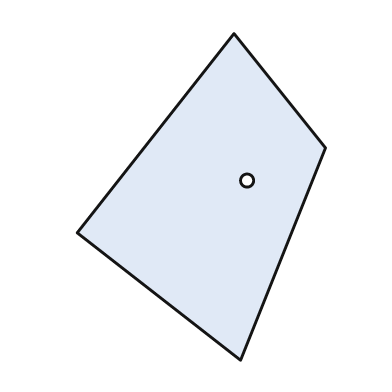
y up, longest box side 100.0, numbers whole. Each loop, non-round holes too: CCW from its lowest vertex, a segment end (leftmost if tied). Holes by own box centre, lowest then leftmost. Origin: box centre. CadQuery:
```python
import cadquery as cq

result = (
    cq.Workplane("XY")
    .moveTo(12.0, -50.0)
    .lineTo(38.0, 15.0)
    .lineTo(10.0, 50.0)
    .lineTo(-38.0, -11.0)
    .close()
    .moveTo(14.0, 5.0)
    .circle(2.0)
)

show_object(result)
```